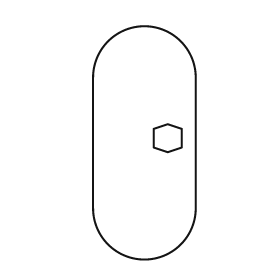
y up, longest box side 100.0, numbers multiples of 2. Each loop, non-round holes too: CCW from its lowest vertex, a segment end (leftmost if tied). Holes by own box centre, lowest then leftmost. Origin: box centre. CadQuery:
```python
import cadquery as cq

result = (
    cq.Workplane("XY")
    .moveTo(-22.0, -28.0)
    .threePointArc((0.0, -50.0), (22.0, -28.0))
    .lineTo(22.0, 28.0)
    .threePointArc((0.0, 50.0), (-22.0, 28.0))
    .close()
    .moveTo(10.0, -4.0)
    .lineTo(16.0, -2.0)
    .lineTo(16.0, 6.0)
    .lineTo(10.0, 8.0)
    .lineTo(4.0, 6.0)
    .lineTo(4.0, -2.0)
    .close()
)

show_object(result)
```